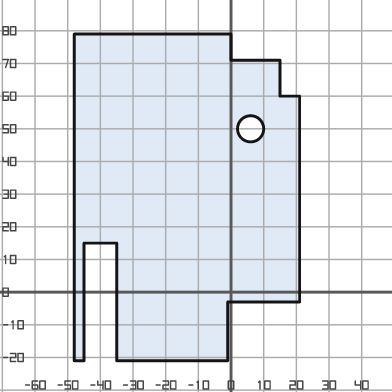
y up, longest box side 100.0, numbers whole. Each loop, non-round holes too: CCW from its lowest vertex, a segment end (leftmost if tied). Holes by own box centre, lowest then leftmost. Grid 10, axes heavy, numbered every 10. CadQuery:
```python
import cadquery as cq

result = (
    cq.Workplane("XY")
    .moveTo(-48.0, -21.0)
    .lineTo(-45.0, -21.0)
    .lineTo(-45.0, 15.0)
    .lineTo(-35.0, 15.0)
    .lineTo(-35.0, -21.0)
    .lineTo(-1.0, -21.0)
    .lineTo(-1.0, -3.0)
    .lineTo(21.0, -3.0)
    .lineTo(21.0, 60.0)
    .lineTo(15.0, 60.0)
    .lineTo(15.0, 71.0)
    .lineTo(0.0, 71.0)
    .lineTo(0.0, 79.0)
    .lineTo(-48.0, 79.0)
    .close()
    .moveTo(6.0, 50.0)
    .circle(4.0)
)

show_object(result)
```